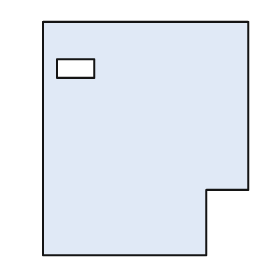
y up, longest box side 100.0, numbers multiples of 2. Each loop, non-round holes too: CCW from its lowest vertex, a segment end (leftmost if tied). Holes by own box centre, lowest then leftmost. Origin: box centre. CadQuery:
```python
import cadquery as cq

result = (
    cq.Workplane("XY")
    .moveTo(-44.0, -50.0)
    .lineTo(26.0, -50.0)
    .lineTo(26.0, -22.0)
    .lineTo(44.0, -22.0)
    .lineTo(44.0, 50.0)
    .lineTo(-44.0, 50.0)
    .close()
    .moveTo(-38.0, 26.0)
    .lineTo(-22.0, 26.0)
    .lineTo(-22.0, 34.0)
    .lineTo(-38.0, 34.0)
    .close()
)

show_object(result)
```